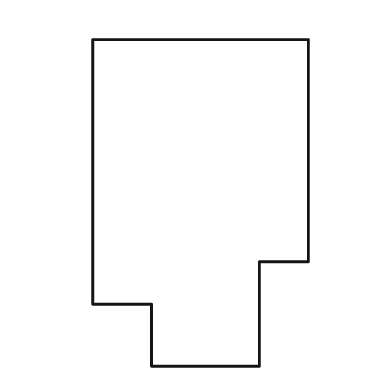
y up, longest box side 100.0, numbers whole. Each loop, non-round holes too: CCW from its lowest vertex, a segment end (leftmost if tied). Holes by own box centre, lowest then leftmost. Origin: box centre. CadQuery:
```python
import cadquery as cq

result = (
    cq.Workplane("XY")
    .moveTo(-15.0, -50.0)
    .lineTo(18.0, -50.0)
    .lineTo(18.0, -18.0)
    .lineTo(33.0, -18.0)
    .lineTo(33.0, 50.0)
    .lineTo(-33.0, 50.0)
    .lineTo(-33.0, -31.0)
    .lineTo(-15.0, -31.0)
    .close()
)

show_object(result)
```